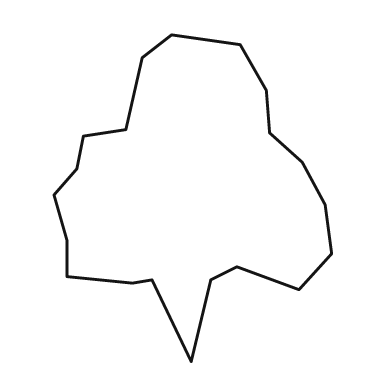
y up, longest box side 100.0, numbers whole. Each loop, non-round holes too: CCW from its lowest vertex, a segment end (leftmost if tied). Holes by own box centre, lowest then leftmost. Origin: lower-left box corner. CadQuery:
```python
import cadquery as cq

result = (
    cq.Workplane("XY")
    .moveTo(42.0, 0.0)
    .lineTo(48.0, 25.0)
    .lineTo(56.0, 29.0)
    .lineTo(75.0, 22.0)
    .lineTo(85.0, 33.0)
    .lineTo(83.0, 48.0)
    .lineTo(76.0, 61.0)
    .lineTo(66.0, 70.0)
    .lineTo(65.0, 83.0)
    .lineTo(57.0, 97.0)
    .lineTo(36.0, 100.0)
    .lineTo(27.0, 93.0)
    .lineTo(22.0, 71.0)
    .lineTo(9.0, 69.0)
    .lineTo(7.0, 59.0)
    .lineTo(0.0, 51.0)
    .lineTo(4.0, 37.0)
    .lineTo(4.0, 26.0)
    .lineTo(24.0, 24.0)
    .lineTo(30.0, 25.0)
    .close()
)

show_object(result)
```